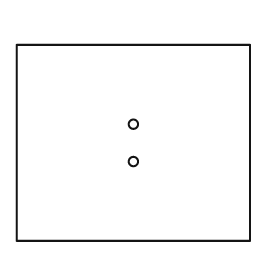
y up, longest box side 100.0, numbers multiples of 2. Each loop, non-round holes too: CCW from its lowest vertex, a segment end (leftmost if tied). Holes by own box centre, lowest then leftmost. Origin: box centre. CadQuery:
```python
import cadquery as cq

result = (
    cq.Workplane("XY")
    .moveTo(-50.0, -42.0)
    .lineTo(50.0, -42.0)
    .lineTo(50.0, 42.0)
    .lineTo(-50.0, 42.0)
    .close()
    .moveTo(0.0, -8.0)
    .circle(2.0)
    .moveTo(0.0, 8.0)
    .circle(2.0)
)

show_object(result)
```